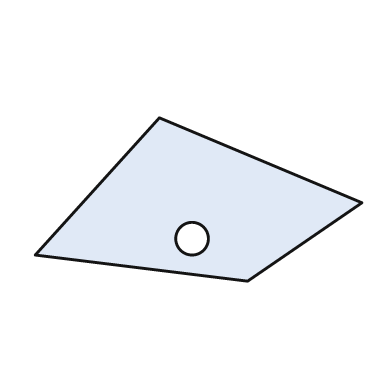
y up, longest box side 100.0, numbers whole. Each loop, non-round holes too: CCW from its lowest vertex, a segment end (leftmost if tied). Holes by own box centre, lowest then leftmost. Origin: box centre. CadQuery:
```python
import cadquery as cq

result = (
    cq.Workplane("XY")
    .moveTo(15.0, -25.0)
    .lineTo(50.0, -1.0)
    .lineTo(-12.0, 25.0)
    .lineTo(-50.0, -17.0)
    .close()
    .moveTo(-2.0, -12.0)
    .circle(5.0)
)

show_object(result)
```